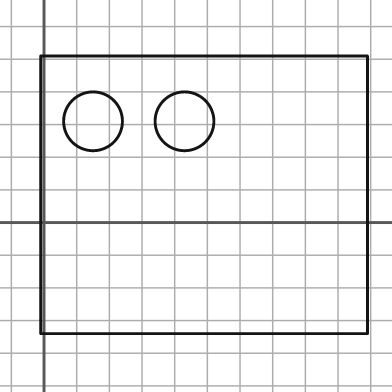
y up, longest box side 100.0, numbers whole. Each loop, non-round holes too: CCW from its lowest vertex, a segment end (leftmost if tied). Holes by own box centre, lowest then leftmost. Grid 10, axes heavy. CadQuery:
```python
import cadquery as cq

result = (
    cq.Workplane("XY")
    .moveTo(-1.0, -34.0)
    .lineTo(99.0, -34.0)
    .lineTo(99.0, 51.0)
    .lineTo(-1.0, 51.0)
    .close()
    .moveTo(15.0, 31.0)
    .circle(9.0)
    .moveTo(43.0, 31.0)
    .circle(9.0)
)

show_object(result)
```